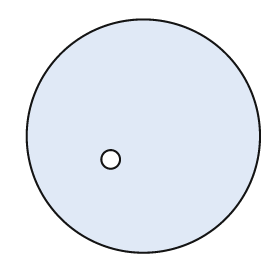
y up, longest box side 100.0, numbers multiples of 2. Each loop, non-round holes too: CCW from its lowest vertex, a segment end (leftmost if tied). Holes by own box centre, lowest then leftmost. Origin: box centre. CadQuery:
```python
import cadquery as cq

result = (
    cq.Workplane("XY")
    .moveTo(0.0, 0.0)
    .circle(50.0)
    .moveTo(-14.0, -10.0)
    .circle(4.0)
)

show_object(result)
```